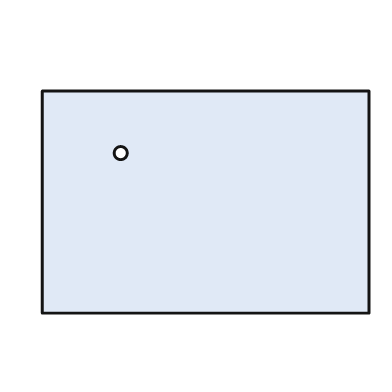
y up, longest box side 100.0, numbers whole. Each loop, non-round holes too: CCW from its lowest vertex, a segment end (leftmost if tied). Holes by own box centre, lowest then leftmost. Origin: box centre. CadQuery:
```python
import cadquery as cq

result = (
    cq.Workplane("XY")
    .moveTo(-50.0, -34.0)
    .lineTo(50.0, -34.0)
    .lineTo(50.0, 34.0)
    .lineTo(-50.0, 34.0)
    .close()
    .moveTo(-26.0, 15.0)
    .circle(2.0)
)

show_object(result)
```